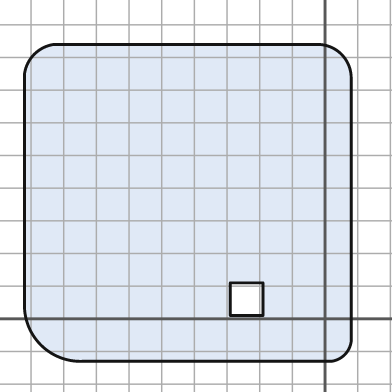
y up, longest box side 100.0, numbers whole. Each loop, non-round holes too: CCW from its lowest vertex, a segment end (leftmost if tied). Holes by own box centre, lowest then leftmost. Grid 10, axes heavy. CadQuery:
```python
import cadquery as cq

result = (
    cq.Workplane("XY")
    .moveTo(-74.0, -13.0)
    .lineTo(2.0, -13.0)
    .threePointArc((6.0, -11.0), (8.0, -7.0))
    .lineTo(8.0, 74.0)
    .threePointArc((5.0, 81.0), (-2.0, 84.0))
    .lineTo(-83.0, 84.0)
    .threePointArc((-89.0, 81.0), (-92.0, 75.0))
    .lineTo(-92.0, 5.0)
    .threePointArc((-87.0, -8.0), (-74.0, -13.0))
    .close()
    .moveTo(-29.0, 1.0)
    .lineTo(-19.0, 1.0)
    .lineTo(-19.0, 11.0)
    .lineTo(-29.0, 11.0)
    .close()
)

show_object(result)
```